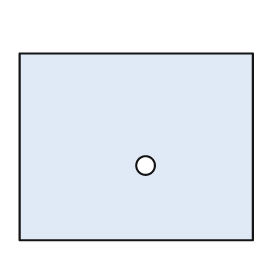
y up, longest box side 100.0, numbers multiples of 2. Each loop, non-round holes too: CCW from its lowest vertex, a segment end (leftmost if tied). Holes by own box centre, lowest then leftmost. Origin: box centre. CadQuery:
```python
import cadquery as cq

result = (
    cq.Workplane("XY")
    .moveTo(-50.0, -40.0)
    .lineTo(50.0, -40.0)
    .lineTo(50.0, 40.0)
    .lineTo(-50.0, 40.0)
    .close()
    .moveTo(4.0, -8.0)
    .circle(4.0)
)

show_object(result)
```